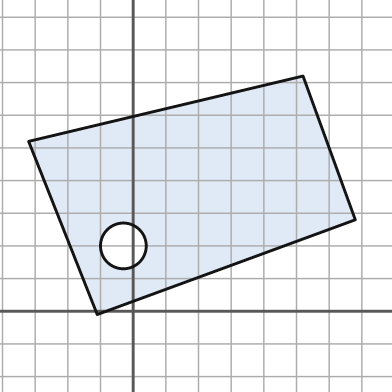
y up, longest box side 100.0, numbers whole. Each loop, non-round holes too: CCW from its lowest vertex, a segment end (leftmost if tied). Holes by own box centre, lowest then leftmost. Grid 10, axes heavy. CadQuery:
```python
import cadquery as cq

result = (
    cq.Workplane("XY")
    .moveTo(-11.0, -1.0)
    .lineTo(68.0, 28.0)
    .lineTo(52.0, 72.0)
    .lineTo(-32.0, 52.0)
    .close()
    .moveTo(-3.0, 20.0)
    .circle(7.0)
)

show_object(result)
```